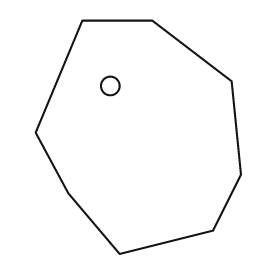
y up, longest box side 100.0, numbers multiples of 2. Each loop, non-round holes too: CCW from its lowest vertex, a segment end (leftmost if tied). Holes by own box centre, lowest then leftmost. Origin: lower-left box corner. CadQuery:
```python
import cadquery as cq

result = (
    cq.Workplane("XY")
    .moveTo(36.0, 0.0)
    .lineTo(76.0, 10.0)
    .lineTo(88.0, 34.0)
    .lineTo(84.0, 74.0)
    .lineTo(50.0, 100.0)
    .lineTo(20.0, 100.0)
    .lineTo(0.0, 52.0)
    .lineTo(14.0, 26.0)
    .close()
    .moveTo(32.0, 72.0)
    .circle(4.0)
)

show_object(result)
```